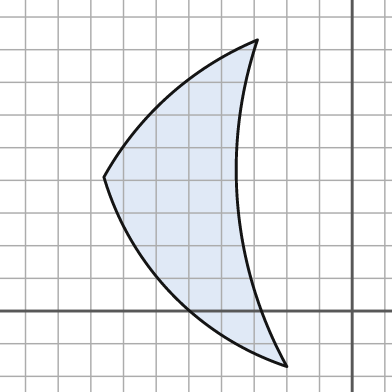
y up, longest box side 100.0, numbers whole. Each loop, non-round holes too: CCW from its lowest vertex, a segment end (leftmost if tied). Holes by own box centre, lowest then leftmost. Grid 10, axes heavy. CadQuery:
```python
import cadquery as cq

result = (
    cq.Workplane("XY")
    .moveTo(-20.0, -17.0)
    .threePointArc((-35.0, 32.0), (-29.0, 83.0))
    .threePointArc((-56.0, 66.0), (-76.0, 41.0))
    .threePointArc((-55.0, 5.0), (-20.0, -17.0))
    .close()
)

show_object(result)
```